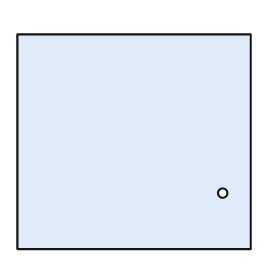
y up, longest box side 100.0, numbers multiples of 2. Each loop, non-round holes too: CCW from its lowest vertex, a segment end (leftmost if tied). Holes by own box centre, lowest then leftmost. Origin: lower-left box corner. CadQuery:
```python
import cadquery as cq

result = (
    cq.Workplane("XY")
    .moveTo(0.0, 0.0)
    .lineTo(100.0, 0.0)
    .lineTo(100.0, 92.0)
    .lineTo(0.0, 92.0)
    .close()
    .moveTo(88.0, 24.0)
    .circle(2.0)
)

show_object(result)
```